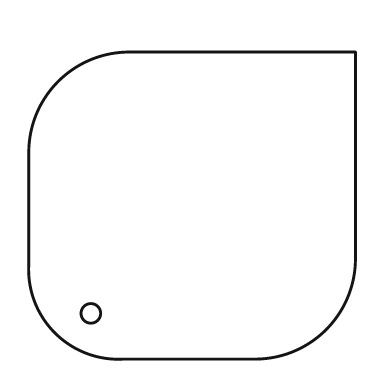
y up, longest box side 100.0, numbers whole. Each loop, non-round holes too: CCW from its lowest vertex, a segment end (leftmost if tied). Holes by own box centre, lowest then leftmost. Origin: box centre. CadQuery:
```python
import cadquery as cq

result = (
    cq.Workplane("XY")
    .moveTo(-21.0, -47.0)
    .lineTo(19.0, -47.0)
    .threePointArc((41.0, -38.0), (50.0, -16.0))
    .lineTo(50.0, 47.0)
    .lineTo(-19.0, 47.0)
    .threePointArc((-41.0, 38.0), (-50.0, 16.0))
    .lineTo(-50.0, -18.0)
    .threePointArc((-42.0, -39.0), (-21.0, -47.0))
    .close()
    .moveTo(-31.0, -33.0)
    .circle(3.0)
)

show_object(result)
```